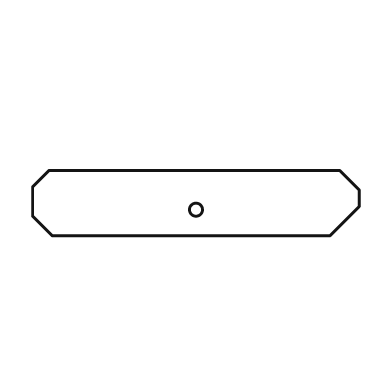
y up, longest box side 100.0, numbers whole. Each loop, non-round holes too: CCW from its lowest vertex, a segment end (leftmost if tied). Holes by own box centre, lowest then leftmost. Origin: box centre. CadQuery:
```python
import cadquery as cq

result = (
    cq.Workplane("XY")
    .moveTo(-44.0, -10.0)
    .lineTo(41.0, -10.0)
    .lineTo(50.0, -1.0)
    .lineTo(50.0, 4.0)
    .lineTo(44.0, 10.0)
    .lineTo(-45.0, 10.0)
    .lineTo(-50.0, 5.0)
    .lineTo(-50.0, -4.0)
    .close()
    .moveTo(0.0, -2.0)
    .circle(2.0)
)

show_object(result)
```